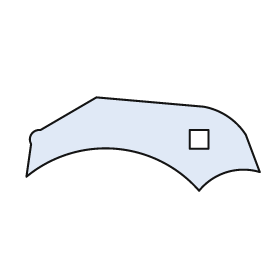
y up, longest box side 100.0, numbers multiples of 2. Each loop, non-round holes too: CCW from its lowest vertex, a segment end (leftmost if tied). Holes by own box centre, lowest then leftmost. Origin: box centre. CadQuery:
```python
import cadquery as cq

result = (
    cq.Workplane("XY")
    .moveTo(24.0, -20.0)
    .threePointArc((36.0, -12.0), (50.0, -12.0))
    .lineTo(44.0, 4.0)
    .threePointArc((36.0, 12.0), (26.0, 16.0))
    .lineTo(-20.0, 20.0)
    .lineTo(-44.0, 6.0)
    .threePointArc((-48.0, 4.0), (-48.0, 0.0))
    .lineTo(-50.0, -14.0)
    .threePointArc((-12.0, -2.0), (24.0, -20.0))
    .close()
    .moveTo(20.0, -2.0)
    .lineTo(28.0, -2.0)
    .lineTo(28.0, 6.0)
    .lineTo(20.0, 6.0)
    .close()
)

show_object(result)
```